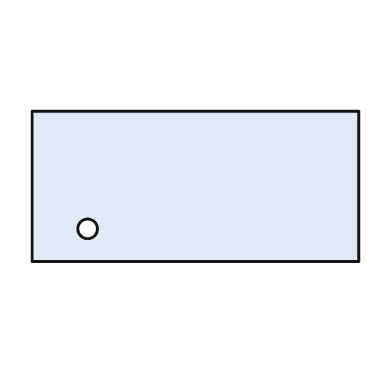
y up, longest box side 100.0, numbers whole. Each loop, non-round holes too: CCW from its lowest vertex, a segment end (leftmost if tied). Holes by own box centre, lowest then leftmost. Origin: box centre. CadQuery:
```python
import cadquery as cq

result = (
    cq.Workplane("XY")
    .moveTo(-50.0, -23.0)
    .lineTo(50.0, -23.0)
    .lineTo(50.0, 23.0)
    .lineTo(-50.0, 23.0)
    .close()
    .moveTo(-33.0, -13.0)
    .circle(3.0)
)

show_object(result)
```